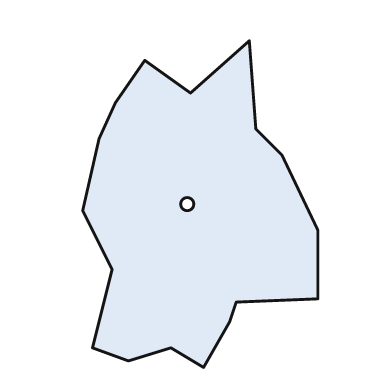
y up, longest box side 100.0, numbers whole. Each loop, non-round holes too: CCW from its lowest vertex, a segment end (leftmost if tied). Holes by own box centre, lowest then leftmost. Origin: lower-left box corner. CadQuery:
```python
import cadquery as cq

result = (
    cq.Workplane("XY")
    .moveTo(37.0, 0.0)
    .lineTo(45.0, 14.0)
    .lineTo(47.0, 20.0)
    .lineTo(72.0, 21.0)
    .lineTo(72.0, 42.0)
    .lineTo(61.0, 65.0)
    .lineTo(53.0, 73.0)
    .lineTo(51.0, 100.0)
    .lineTo(33.0, 84.0)
    .lineTo(19.0, 94.0)
    .lineTo(10.0, 81.0)
    .lineTo(5.0, 70.0)
    .lineTo(0.0, 48.0)
    .lineTo(9.0, 30.0)
    .lineTo(3.0, 6.0)
    .lineTo(14.0, 2.0)
    .lineTo(27.0, 6.0)
    .close()
    .moveTo(32.0, 50.0)
    .circle(2.0)
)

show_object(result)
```